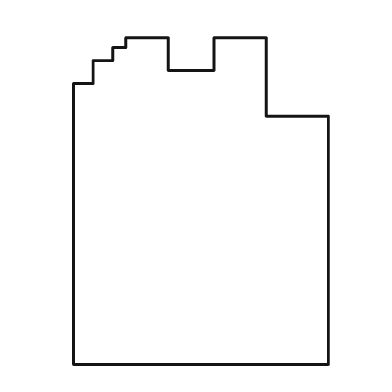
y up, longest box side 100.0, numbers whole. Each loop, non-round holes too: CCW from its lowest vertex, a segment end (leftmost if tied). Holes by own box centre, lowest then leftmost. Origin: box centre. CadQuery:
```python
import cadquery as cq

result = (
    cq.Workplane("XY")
    .moveTo(-39.0, -50.0)
    .lineTo(39.0, -50.0)
    .lineTo(39.0, 26.0)
    .lineTo(20.0, 26.0)
    .lineTo(20.0, 50.0)
    .lineTo(4.0, 50.0)
    .lineTo(4.0, 40.0)
    .lineTo(-10.0, 40.0)
    .lineTo(-10.0, 50.0)
    .lineTo(-23.0, 50.0)
    .lineTo(-23.0, 47.0)
    .lineTo(-27.0, 47.0)
    .lineTo(-27.0, 43.0)
    .lineTo(-33.0, 43.0)
    .lineTo(-33.0, 36.0)
    .lineTo(-39.0, 36.0)
    .close()
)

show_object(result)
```